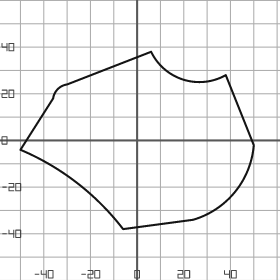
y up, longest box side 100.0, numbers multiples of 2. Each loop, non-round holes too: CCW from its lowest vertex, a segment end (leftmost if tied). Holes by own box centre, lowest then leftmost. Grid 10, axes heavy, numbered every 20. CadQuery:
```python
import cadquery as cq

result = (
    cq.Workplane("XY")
    .moveTo(-6.0, -38.0)
    .lineTo(24.0, -34.0)
    .threePointArc((42.0, -22.0), (50.0, -2.0))
    .lineTo(38.0, 28.0)
    .threePointArc((20.0, 26.0), (6.0, 38.0))
    .lineTo(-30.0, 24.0)
    .threePointArc((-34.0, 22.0), (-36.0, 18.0))
    .lineTo(-50.0, -4.0)
    .threePointArc((-26.0, -18.0), (-6.0, -38.0))
    .close()
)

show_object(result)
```